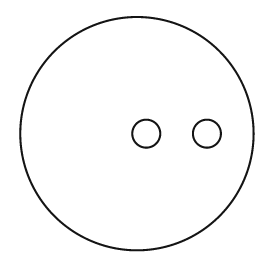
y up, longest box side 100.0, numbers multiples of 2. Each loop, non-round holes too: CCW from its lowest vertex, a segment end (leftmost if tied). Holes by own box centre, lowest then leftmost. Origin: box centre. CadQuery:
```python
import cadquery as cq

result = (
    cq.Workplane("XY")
    .moveTo(0.0, 0.0)
    .circle(50.0)
    .moveTo(4.0, 0.0)
    .circle(6.0)
    .moveTo(30.0, 0.0)
    .circle(6.0)
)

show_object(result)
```